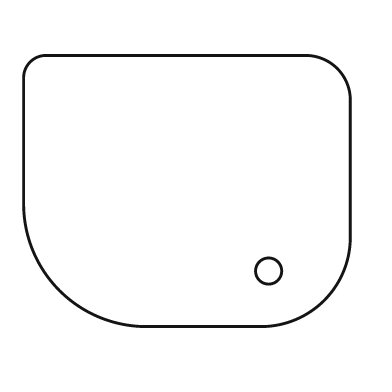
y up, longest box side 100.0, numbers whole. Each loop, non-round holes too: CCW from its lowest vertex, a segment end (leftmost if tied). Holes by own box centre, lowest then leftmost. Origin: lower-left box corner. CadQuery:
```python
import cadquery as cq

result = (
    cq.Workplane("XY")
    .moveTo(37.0, 0.0)
    .lineTo(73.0, 0.0)
    .threePointArc((92.0, 8.0), (100.0, 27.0))
    .lineTo(100.0, 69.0)
    .threePointArc((96.0, 79.0), (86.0, 83.0))
    .lineTo(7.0, 83.0)
    .threePointArc((2.0, 81.0), (0.0, 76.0))
    .lineTo(0.0, 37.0)
    .threePointArc((11.0, 11.0), (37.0, 0.0))
    .close()
    .moveTo(75.0, 17.0)
    .circle(4.0)
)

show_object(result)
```